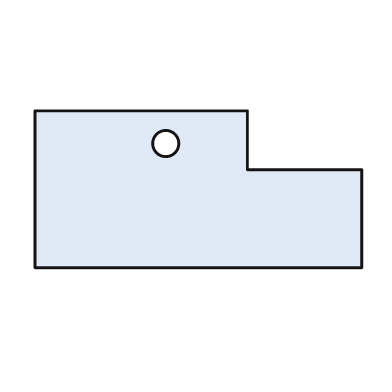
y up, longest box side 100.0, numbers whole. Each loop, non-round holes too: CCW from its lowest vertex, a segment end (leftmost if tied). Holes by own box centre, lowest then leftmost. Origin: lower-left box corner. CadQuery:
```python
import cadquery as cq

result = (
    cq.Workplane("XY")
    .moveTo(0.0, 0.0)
    .lineTo(100.0, 0.0)
    .lineTo(100.0, 30.0)
    .lineTo(65.0, 30.0)
    .lineTo(65.0, 48.0)
    .lineTo(0.0, 48.0)
    .close()
    .moveTo(40.0, 38.0)
    .circle(4.0)
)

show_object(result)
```